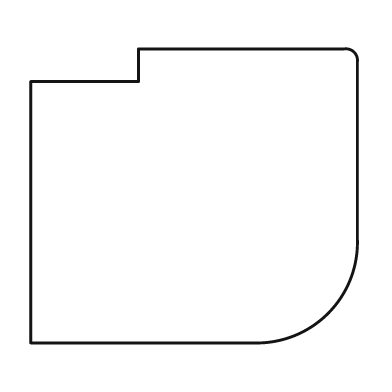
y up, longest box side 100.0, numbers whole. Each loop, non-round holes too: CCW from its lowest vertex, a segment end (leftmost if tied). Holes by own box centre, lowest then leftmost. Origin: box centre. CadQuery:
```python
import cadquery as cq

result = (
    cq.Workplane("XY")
    .moveTo(-50.0, -45.0)
    .lineTo(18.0, -45.0)
    .threePointArc((41.0, -36.0), (50.0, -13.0))
    .lineTo(50.0, 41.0)
    .threePointArc((49.0, 44.0), (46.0, 45.0))
    .lineTo(-17.0, 45.0)
    .lineTo(-17.0, 35.0)
    .lineTo(-50.0, 35.0)
    .close()
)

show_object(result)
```